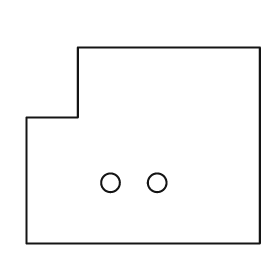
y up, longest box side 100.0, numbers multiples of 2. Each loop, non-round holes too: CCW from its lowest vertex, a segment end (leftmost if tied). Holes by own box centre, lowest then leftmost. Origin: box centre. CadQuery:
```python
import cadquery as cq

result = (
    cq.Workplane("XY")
    .moveTo(-50.0, -42.0)
    .lineTo(50.0, -42.0)
    .lineTo(50.0, 42.0)
    .lineTo(-28.0, 42.0)
    .lineTo(-28.0, 12.0)
    .lineTo(-50.0, 12.0)
    .close()
    .moveTo(-14.0, -16.0)
    .circle(4.0)
    .moveTo(6.0, -16.0)
    .circle(4.0)
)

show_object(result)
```